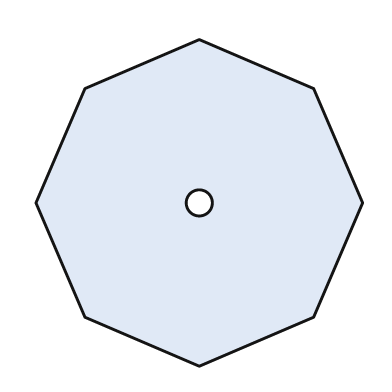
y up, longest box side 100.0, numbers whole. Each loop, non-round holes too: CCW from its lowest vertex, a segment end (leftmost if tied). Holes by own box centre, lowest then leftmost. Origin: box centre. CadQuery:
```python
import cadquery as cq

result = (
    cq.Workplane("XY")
    .moveTo(0.0, -50.0)
    .lineTo(35.0, -35.0)
    .lineTo(50.0, 0.0)
    .lineTo(35.0, 35.0)
    .lineTo(0.0, 50.0)
    .lineTo(-35.0, 35.0)
    .lineTo(-50.0, 0.0)
    .lineTo(-35.0, -35.0)
    .close()
    .moveTo(0.0, 0.0)
    .circle(4.0)
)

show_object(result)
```